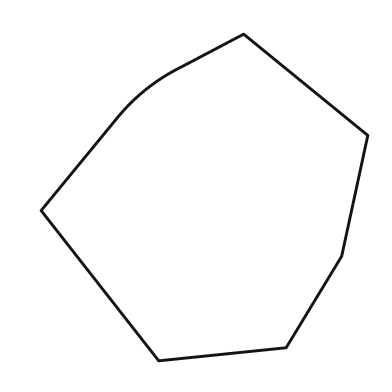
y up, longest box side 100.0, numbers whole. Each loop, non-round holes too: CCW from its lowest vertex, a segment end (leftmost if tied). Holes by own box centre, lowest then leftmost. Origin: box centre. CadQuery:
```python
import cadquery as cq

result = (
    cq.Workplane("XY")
    .moveTo(-14.0, -50.0)
    .lineTo(25.0, -46.0)
    .lineTo(42.0, -18.0)
    .lineTo(50.0, 19.0)
    .lineTo(12.0, 50.0)
    .lineTo(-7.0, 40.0)
    .threePointArc((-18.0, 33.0), (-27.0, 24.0))
    .lineTo(-50.0, -4.0)
    .close()
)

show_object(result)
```